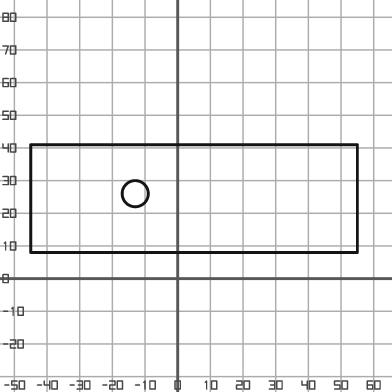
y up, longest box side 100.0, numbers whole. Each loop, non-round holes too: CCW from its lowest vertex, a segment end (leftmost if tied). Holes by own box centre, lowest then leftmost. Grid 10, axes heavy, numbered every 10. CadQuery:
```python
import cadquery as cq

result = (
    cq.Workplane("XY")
    .moveTo(-45.0, 8.0)
    .lineTo(55.0, 8.0)
    .lineTo(55.0, 41.0)
    .lineTo(-45.0, 41.0)
    .close()
    .moveTo(-13.0, 26.0)
    .circle(4.0)
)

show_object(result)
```